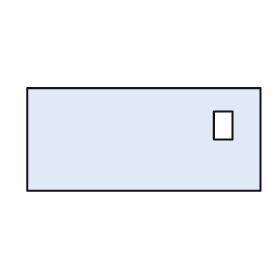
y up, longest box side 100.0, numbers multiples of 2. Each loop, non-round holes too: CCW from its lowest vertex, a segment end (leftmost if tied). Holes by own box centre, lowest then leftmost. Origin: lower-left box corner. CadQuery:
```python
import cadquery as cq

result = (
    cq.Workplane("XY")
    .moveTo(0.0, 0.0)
    .lineTo(100.0, 0.0)
    .lineTo(100.0, 44.0)
    .lineTo(0.0, 44.0)
    .close()
    .moveTo(80.0, 22.0)
    .lineTo(88.0, 22.0)
    .lineTo(88.0, 34.0)
    .lineTo(80.0, 34.0)
    .close()
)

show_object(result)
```